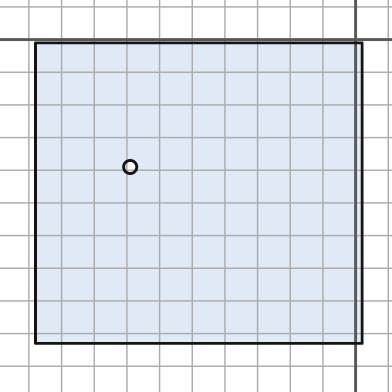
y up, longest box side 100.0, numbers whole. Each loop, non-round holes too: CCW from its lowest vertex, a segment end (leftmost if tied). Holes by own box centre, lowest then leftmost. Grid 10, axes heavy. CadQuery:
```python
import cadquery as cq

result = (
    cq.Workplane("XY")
    .moveTo(-98.0, -93.0)
    .lineTo(2.0, -93.0)
    .lineTo(2.0, -1.0)
    .lineTo(-98.0, -1.0)
    .close()
    .moveTo(-69.0, -39.0)
    .circle(2.0)
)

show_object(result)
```